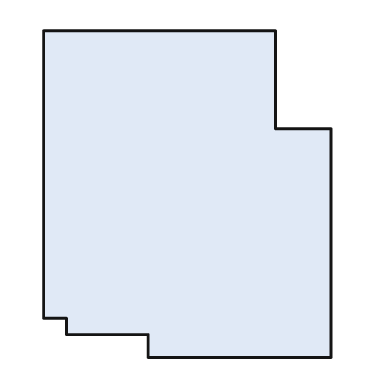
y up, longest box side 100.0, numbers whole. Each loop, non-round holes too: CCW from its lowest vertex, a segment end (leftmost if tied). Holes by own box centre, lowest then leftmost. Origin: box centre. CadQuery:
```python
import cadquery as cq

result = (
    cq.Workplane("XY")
    .moveTo(-12.0, -50.0)
    .lineTo(44.0, -50.0)
    .lineTo(44.0, 20.0)
    .lineTo(27.0, 20.0)
    .lineTo(27.0, 50.0)
    .lineTo(-44.0, 50.0)
    .lineTo(-44.0, -38.0)
    .lineTo(-37.0, -38.0)
    .lineTo(-37.0, -43.0)
    .lineTo(-12.0, -43.0)
    .close()
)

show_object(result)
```